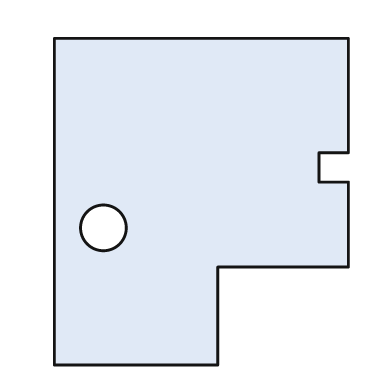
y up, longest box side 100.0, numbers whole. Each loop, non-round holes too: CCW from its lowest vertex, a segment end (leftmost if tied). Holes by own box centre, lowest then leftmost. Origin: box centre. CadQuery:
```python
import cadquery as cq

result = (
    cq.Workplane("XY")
    .moveTo(-45.0, -50.0)
    .lineTo(5.0, -50.0)
    .lineTo(5.0, -20.0)
    .lineTo(45.0, -20.0)
    .lineTo(45.0, 6.0)
    .lineTo(36.0, 6.0)
    .lineTo(36.0, 15.0)
    .lineTo(45.0, 15.0)
    .lineTo(45.0, 50.0)
    .lineTo(-45.0, 50.0)
    .close()
    .moveTo(-30.0, -8.0)
    .circle(7.0)
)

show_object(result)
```